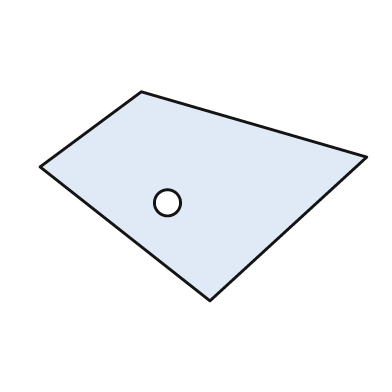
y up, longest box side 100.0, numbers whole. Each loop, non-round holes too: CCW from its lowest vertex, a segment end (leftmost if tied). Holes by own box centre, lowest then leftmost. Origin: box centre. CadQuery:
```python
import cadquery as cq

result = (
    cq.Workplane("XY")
    .moveTo(2.0, -32.0)
    .lineTo(50.0, 12.0)
    .lineTo(-19.0, 32.0)
    .lineTo(-50.0, 9.0)
    .close()
    .moveTo(-11.0, -2.0)
    .circle(4.0)
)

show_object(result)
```